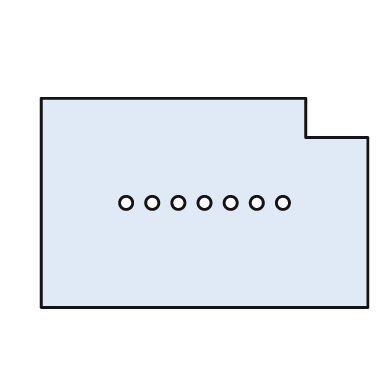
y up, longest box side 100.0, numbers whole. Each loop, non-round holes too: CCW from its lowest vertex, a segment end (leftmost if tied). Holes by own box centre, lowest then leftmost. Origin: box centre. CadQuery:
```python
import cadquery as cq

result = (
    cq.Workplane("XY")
    .moveTo(-50.0, -32.0)
    .lineTo(50.0, -32.0)
    .lineTo(50.0, 20.0)
    .lineTo(31.0, 20.0)
    .lineTo(31.0, 32.0)
    .lineTo(-50.0, 32.0)
    .close()
    .moveTo(-24.0, 0.0)
    .circle(2.0)
    .moveTo(-16.0, 0.0)
    .circle(2.0)
    .moveTo(-8.0, 0.0)
    .circle(2.0)
    .moveTo(0.0, 0.0)
    .circle(2.0)
    .moveTo(8.0, 0.0)
    .circle(2.0)
    .moveTo(16.0, 0.0)
    .circle(2.0)
    .moveTo(24.0, 0.0)
    .circle(2.0)
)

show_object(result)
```